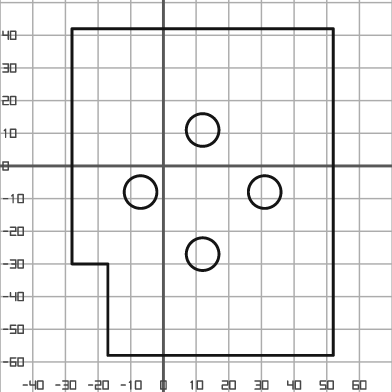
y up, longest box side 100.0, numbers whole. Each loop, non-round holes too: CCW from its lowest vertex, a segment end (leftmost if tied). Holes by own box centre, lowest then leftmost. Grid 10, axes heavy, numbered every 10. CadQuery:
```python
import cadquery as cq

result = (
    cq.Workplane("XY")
    .moveTo(-17.0, -58.0)
    .lineTo(52.0, -58.0)
    .lineTo(52.0, 42.0)
    .lineTo(-28.0, 42.0)
    .lineTo(-28.0, -30.0)
    .lineTo(-17.0, -30.0)
    .close()
    .moveTo(12.0, -27.0)
    .circle(5.0)
    .moveTo(-7.0, -8.0)
    .circle(5.0)
    .moveTo(31.0, -8.0)
    .circle(5.0)
    .moveTo(12.0, 11.0)
    .circle(5.0)
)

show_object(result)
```